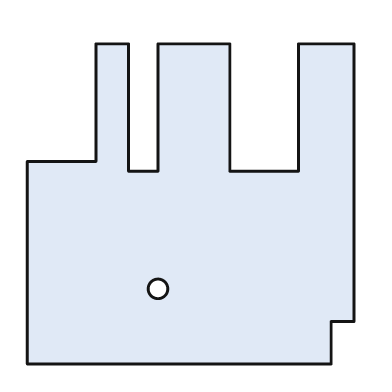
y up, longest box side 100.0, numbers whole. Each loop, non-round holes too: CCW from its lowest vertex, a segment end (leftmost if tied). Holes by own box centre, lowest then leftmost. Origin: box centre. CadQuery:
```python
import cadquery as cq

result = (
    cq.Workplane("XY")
    .moveTo(-50.0, -49.0)
    .lineTo(43.0, -49.0)
    .lineTo(43.0, -36.0)
    .lineTo(50.0, -36.0)
    .lineTo(50.0, 49.0)
    .lineTo(33.0, 49.0)
    .lineTo(33.0, 10.0)
    .lineTo(12.0, 10.0)
    .lineTo(12.0, 49.0)
    .lineTo(-10.0, 49.0)
    .lineTo(-10.0, 10.0)
    .lineTo(-19.0, 10.0)
    .lineTo(-19.0, 49.0)
    .lineTo(-29.0, 49.0)
    .lineTo(-29.0, 13.0)
    .lineTo(-50.0, 13.0)
    .close()
    .moveTo(-10.0, -26.0)
    .circle(3.0)
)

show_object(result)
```